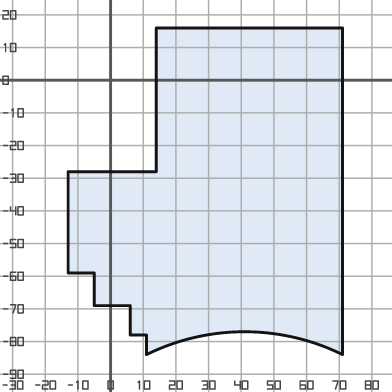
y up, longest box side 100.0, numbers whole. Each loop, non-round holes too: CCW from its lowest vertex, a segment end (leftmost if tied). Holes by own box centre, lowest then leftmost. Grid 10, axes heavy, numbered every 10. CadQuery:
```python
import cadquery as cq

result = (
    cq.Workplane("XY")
    .moveTo(11.0, -84.0)
    .threePointArc((41.0, -77.0), (71.0, -84.0))
    .lineTo(71.0, 16.0)
    .lineTo(14.0, 16.0)
    .lineTo(14.0, -28.0)
    .lineTo(-13.0, -28.0)
    .lineTo(-13.0, -59.0)
    .lineTo(-5.0, -59.0)
    .lineTo(-5.0, -69.0)
    .lineTo(6.0, -69.0)
    .lineTo(6.0, -78.0)
    .lineTo(11.0, -78.0)
    .close()
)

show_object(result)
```